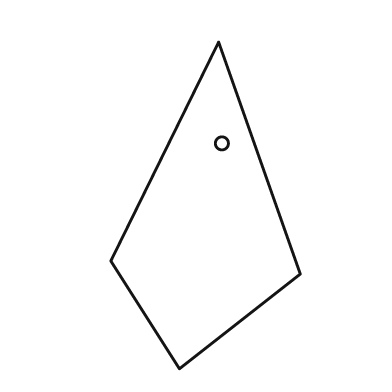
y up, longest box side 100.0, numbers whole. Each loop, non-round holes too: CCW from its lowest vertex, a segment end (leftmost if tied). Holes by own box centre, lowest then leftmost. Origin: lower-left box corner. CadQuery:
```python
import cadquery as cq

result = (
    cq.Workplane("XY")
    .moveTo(21.0, 0.0)
    .lineTo(58.0, 29.0)
    .lineTo(33.0, 100.0)
    .lineTo(0.0, 33.0)
    .close()
    .moveTo(34.0, 69.0)
    .circle(2.0)
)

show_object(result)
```